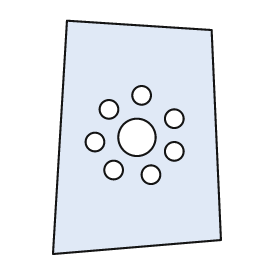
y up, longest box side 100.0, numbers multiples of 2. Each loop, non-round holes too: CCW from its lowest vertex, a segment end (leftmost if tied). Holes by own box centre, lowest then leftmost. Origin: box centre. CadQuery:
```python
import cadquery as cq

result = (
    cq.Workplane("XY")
    .moveTo(-36.0, -50.0)
    .lineTo(36.0, -44.0)
    .lineTo(32.0, 46.0)
    .lineTo(-30.0, 50.0)
    .close()
    .moveTo(6.0, -16.0)
    .circle(4.0)
    .moveTo(-10.0, -14.0)
    .circle(4.0)
    .moveTo(16.0, -6.0)
    .circle(4.0)
    .moveTo(-18.0, -2.0)
    .circle(4.0)
    .moveTo(0.0, 0.0)
    .circle(8.0)
    .moveTo(16.0, 8.0)
    .circle(4.0)
    .moveTo(-12.0, 12.0)
    .circle(4.0)
    .moveTo(2.0, 18.0)
    .circle(4.0)
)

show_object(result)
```